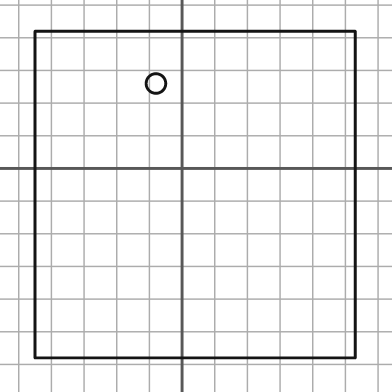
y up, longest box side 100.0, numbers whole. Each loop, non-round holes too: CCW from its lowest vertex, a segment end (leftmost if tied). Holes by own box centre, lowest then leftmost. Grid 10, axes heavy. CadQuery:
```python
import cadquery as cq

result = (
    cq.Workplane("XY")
    .moveTo(-45.0, -58.0)
    .lineTo(53.0, -58.0)
    .lineTo(53.0, 42.0)
    .lineTo(-45.0, 42.0)
    .close()
    .moveTo(-8.0, 26.0)
    .circle(3.0)
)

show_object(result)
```